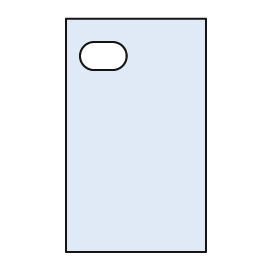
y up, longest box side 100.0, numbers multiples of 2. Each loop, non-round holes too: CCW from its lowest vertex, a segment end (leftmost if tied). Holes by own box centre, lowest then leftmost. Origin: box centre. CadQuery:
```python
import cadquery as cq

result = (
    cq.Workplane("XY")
    .moveTo(-30.0, -50.0)
    .lineTo(30.0, -50.0)
    .lineTo(30.0, 50.0)
    .lineTo(-30.0, 50.0)
    .close()
    .moveTo(-18.0, 28.0)
    .lineTo(-10.0, 28.0)
    .threePointArc((-4.0, 34.0), (-10.0, 40.0))
    .lineTo(-18.0, 40.0)
    .threePointArc((-24.0, 34.0), (-18.0, 28.0))
    .close()
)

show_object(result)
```